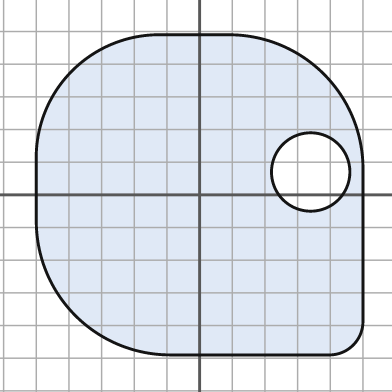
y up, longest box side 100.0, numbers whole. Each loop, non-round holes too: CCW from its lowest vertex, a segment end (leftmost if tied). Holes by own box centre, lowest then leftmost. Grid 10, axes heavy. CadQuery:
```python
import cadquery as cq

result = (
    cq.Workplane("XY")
    .moveTo(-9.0, -49.0)
    .lineTo(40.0, -49.0)
    .threePointArc((47.0, -46.0), (50.0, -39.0))
    .lineTo(50.0, 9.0)
    .threePointArc((38.0, 37.0), (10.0, 49.0))
    .lineTo(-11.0, 49.0)
    .threePointArc((-39.0, 38.0), (-50.0, 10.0))
    .lineTo(-50.0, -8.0)
    .threePointArc((-38.0, -37.0), (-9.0, -49.0))
    .close()
    .moveTo(34.0, 7.0)
    .circle(12.0)
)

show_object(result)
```